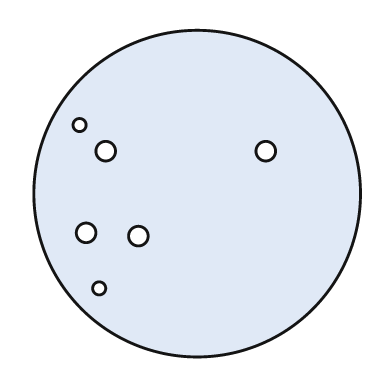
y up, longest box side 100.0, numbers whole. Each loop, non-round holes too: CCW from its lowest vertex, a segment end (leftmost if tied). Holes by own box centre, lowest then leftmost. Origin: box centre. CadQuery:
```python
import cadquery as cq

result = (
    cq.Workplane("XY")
    .moveTo(0.0, 0.0)
    .circle(50.0)
    .moveTo(-30.0, -29.0)
    .circle(2.0)
    .moveTo(-18.0, -13.0)
    .circle(3.0)
    .moveTo(-34.0, -12.0)
    .circle(3.0)
    .moveTo(-28.0, 13.0)
    .circle(3.0)
    .moveTo(21.0, 13.0)
    .circle(3.0)
    .moveTo(-36.0, 21.0)
    .circle(2.0)
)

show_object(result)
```